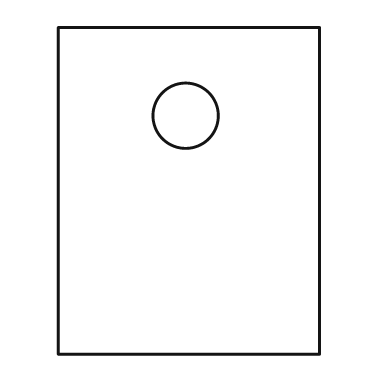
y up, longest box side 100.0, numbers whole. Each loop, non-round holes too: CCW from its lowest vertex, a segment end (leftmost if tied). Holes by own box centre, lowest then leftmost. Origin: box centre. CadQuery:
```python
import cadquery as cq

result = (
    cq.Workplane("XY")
    .moveTo(-40.0, -50.0)
    .lineTo(40.0, -50.0)
    .lineTo(40.0, 50.0)
    .lineTo(-40.0, 50.0)
    .close()
    .moveTo(-1.0, 23.0)
    .circle(10.0)
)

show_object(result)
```